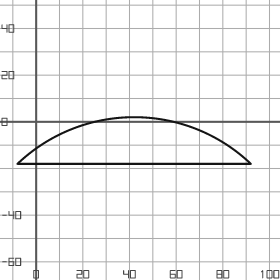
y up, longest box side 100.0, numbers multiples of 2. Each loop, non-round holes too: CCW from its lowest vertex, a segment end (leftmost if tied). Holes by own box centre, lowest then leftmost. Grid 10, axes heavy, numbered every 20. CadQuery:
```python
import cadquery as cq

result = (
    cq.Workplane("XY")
    .moveTo(-8.0, -18.0)
    .lineTo(92.0, -18.0)
    .threePointArc((42.0, 2.0), (-8.0, -18.0))
    .close()
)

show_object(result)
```